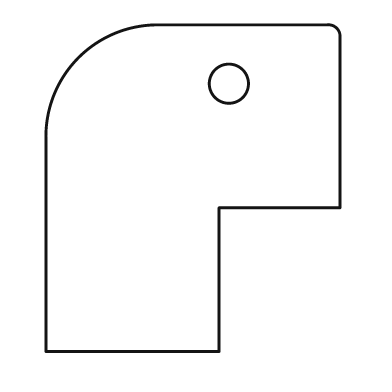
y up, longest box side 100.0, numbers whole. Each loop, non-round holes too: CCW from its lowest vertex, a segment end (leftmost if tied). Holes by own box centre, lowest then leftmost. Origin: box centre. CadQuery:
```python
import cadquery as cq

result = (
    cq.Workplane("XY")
    .moveTo(-45.0, -50.0)
    .lineTo(8.0, -50.0)
    .lineTo(8.0, -6.0)
    .lineTo(45.0, -6.0)
    .lineTo(45.0, 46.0)
    .threePointArc((44.0, 49.0), (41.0, 50.0))
    .lineTo(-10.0, 50.0)
    .threePointArc((-35.0, 40.0), (-45.0, 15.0))
    .close()
    .moveTo(11.0, 32.0)
    .circle(6.0)
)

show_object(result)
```